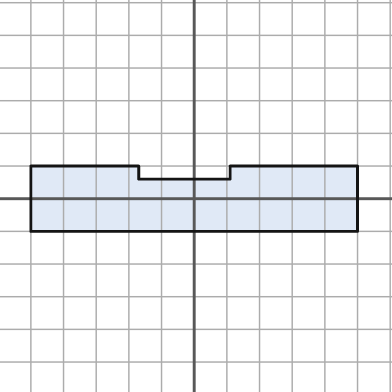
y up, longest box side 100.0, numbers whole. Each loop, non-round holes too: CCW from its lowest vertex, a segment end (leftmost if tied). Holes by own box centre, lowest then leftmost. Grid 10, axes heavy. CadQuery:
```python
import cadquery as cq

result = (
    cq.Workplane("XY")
    .moveTo(-50.0, -10.0)
    .lineTo(50.0, -10.0)
    .lineTo(50.0, 10.0)
    .lineTo(11.0, 10.0)
    .lineTo(11.0, 6.0)
    .lineTo(-17.0, 6.0)
    .lineTo(-17.0, 10.0)
    .lineTo(-50.0, 10.0)
    .close()
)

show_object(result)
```